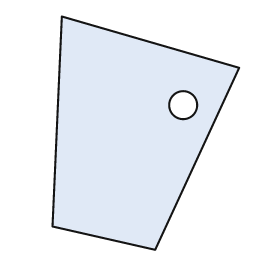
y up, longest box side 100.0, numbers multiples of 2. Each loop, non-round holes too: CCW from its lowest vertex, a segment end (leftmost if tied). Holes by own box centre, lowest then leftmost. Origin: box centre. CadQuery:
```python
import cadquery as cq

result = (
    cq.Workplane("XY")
    .moveTo(4.0, -50.0)
    .lineTo(40.0, 28.0)
    .lineTo(-36.0, 50.0)
    .lineTo(-40.0, -40.0)
    .close()
    .moveTo(16.0, 12.0)
    .circle(6.0)
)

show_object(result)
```